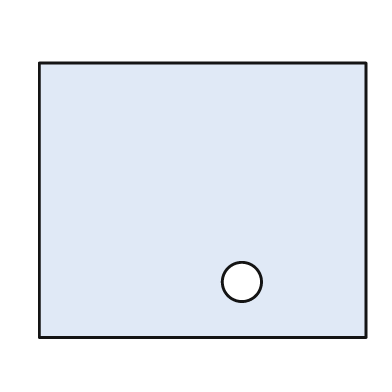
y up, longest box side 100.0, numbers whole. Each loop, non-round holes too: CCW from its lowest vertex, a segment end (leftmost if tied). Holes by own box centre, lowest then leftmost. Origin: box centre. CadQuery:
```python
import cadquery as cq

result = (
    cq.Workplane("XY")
    .moveTo(-50.0, -42.0)
    .lineTo(50.0, -42.0)
    .lineTo(50.0, 42.0)
    .lineTo(-50.0, 42.0)
    .close()
    .moveTo(12.0, -25.0)
    .circle(6.0)
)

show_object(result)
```